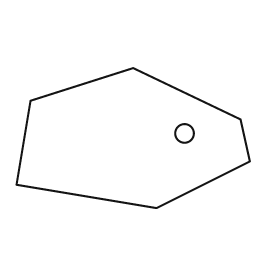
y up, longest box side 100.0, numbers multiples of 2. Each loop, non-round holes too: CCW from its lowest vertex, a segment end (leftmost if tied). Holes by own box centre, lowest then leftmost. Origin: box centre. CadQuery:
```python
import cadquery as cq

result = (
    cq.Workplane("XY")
    .moveTo(10.0, -30.0)
    .lineTo(50.0, -10.0)
    .lineTo(46.0, 8.0)
    .lineTo(0.0, 30.0)
    .lineTo(-44.0, 16.0)
    .lineTo(-50.0, -20.0)
    .close()
    .moveTo(22.0, 2.0)
    .circle(4.0)
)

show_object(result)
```